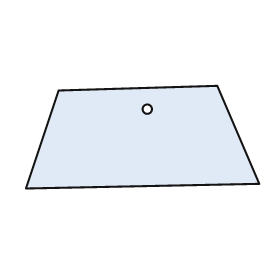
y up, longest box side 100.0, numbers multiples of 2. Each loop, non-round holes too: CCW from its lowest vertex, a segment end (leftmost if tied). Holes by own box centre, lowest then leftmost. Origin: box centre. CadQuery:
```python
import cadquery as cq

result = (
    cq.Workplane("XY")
    .moveTo(-50.0, -22.0)
    .lineTo(50.0, -20.0)
    .lineTo(32.0, 22.0)
    .lineTo(-36.0, 20.0)
    .close()
    .moveTo(2.0, 12.0)
    .circle(2.0)
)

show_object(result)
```